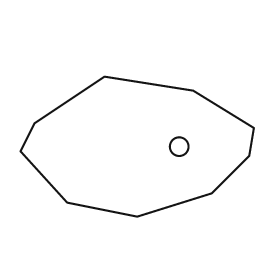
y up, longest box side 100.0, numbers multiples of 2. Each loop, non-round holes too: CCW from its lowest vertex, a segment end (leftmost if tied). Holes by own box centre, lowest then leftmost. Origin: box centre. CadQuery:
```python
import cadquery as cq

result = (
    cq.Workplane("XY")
    .moveTo(0.0, -30.0)
    .lineTo(32.0, -20.0)
    .lineTo(48.0, -4.0)
    .lineTo(50.0, 8.0)
    .lineTo(24.0, 24.0)
    .lineTo(-14.0, 30.0)
    .lineTo(-44.0, 10.0)
    .lineTo(-50.0, -2.0)
    .lineTo(-30.0, -24.0)
    .close()
    .moveTo(18.0, 0.0)
    .circle(4.0)
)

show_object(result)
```